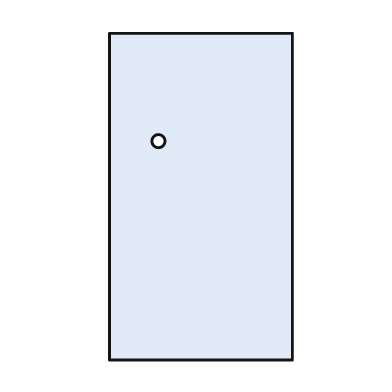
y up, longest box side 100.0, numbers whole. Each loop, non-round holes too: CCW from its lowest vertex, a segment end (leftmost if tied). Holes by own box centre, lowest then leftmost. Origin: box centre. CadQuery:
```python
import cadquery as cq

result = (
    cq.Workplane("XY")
    .moveTo(-28.0, -50.0)
    .lineTo(28.0, -50.0)
    .lineTo(28.0, 50.0)
    .lineTo(-28.0, 50.0)
    .close()
    .moveTo(-13.0, 17.0)
    .circle(2.0)
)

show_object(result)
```